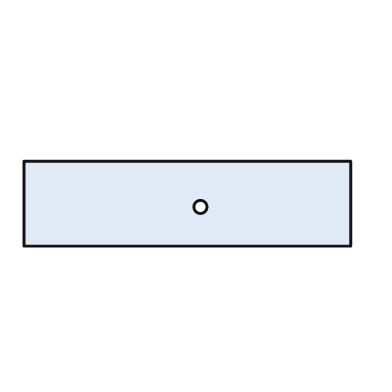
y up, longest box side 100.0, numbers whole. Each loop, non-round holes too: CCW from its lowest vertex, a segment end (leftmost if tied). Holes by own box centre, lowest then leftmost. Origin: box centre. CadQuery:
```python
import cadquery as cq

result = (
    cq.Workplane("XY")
    .moveTo(-50.0, -13.0)
    .lineTo(50.0, -13.0)
    .lineTo(50.0, 13.0)
    .lineTo(-50.0, 13.0)
    .close()
    .moveTo(4.0, -1.0)
    .circle(2.0)
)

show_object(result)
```